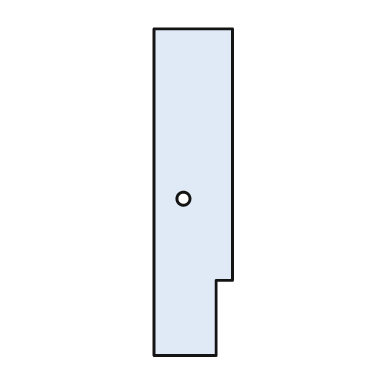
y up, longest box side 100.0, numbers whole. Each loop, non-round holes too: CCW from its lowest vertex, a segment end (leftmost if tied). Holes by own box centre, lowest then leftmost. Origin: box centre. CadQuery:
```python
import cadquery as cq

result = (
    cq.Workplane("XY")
    .moveTo(-12.0, -50.0)
    .lineTo(7.0, -50.0)
    .lineTo(7.0, -27.0)
    .lineTo(12.0, -27.0)
    .lineTo(12.0, 50.0)
    .lineTo(-12.0, 50.0)
    .close()
    .moveTo(-3.0, -2.0)
    .circle(2.0)
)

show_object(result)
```